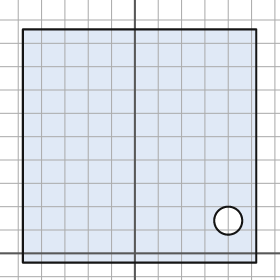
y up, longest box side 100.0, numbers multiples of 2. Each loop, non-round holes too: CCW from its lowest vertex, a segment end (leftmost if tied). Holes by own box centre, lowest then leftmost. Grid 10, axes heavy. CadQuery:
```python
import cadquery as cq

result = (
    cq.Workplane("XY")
    .moveTo(-48.0, -4.0)
    .lineTo(52.0, -4.0)
    .lineTo(52.0, 96.0)
    .lineTo(-48.0, 96.0)
    .close()
    .moveTo(40.0, 14.0)
    .circle(6.0)
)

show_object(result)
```